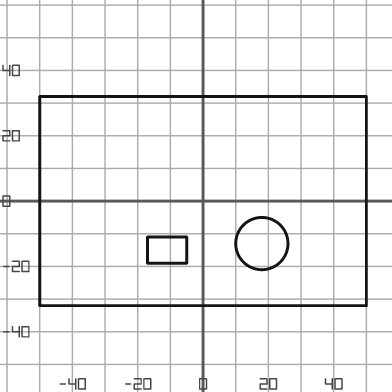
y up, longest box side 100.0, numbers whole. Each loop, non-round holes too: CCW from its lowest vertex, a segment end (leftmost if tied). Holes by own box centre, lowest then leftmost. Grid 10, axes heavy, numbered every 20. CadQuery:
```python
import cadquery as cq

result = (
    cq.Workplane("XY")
    .moveTo(-50.0, -32.0)
    .lineTo(50.0, -32.0)
    .lineTo(50.0, 32.0)
    .lineTo(-50.0, 32.0)
    .close()
    .moveTo(-17.0, -19.0)
    .lineTo(-5.0, -19.0)
    .lineTo(-5.0, -11.0)
    .lineTo(-17.0, -11.0)
    .close()
    .moveTo(18.0, -13.0)
    .circle(8.0)
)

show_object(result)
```